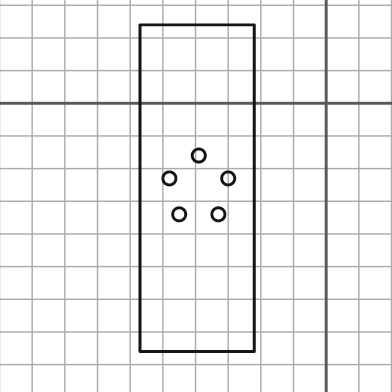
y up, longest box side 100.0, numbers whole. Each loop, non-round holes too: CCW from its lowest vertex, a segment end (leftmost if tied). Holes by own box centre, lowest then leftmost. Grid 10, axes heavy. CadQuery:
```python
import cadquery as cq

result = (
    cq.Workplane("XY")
    .moveTo(-57.0, -76.0)
    .lineTo(-22.0, -76.0)
    .lineTo(-22.0, 24.0)
    .lineTo(-57.0, 24.0)
    .close()
    .moveTo(-45.0, -34.0)
    .circle(2.0)
    .moveTo(-33.0, -34.0)
    .circle(2.0)
    .moveTo(-48.0, -23.0)
    .circle(2.0)
    .moveTo(-30.0, -23.0)
    .circle(2.0)
    .moveTo(-39.0, -16.0)
    .circle(2.0)
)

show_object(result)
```